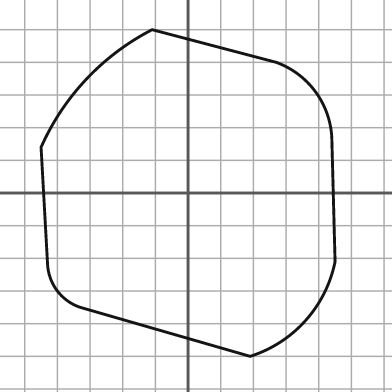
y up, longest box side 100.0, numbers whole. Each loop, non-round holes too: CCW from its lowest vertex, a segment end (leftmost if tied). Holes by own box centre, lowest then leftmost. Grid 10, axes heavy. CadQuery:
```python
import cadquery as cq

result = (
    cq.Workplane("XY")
    .moveTo(19.0, -50.0)
    .threePointArc((36.0, -39.0), (45.0, -21.0))
    .lineTo(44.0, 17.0)
    .threePointArc((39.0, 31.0), (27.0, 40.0))
    .lineTo(-11.0, 50.0)
    .threePointArc((-31.0, 35.0), (-45.0, 14.0))
    .lineTo(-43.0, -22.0)
    .threePointArc((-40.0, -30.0), (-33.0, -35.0))
    .close()
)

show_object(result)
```